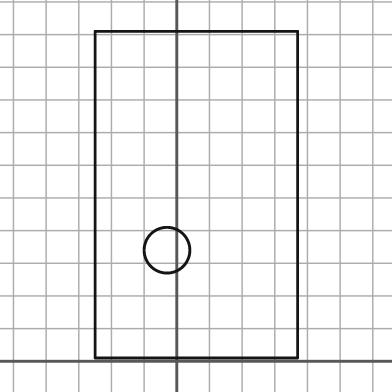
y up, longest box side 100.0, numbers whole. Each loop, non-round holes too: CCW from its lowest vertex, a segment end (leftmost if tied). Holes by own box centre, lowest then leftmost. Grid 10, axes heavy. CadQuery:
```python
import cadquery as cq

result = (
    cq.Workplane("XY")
    .moveTo(-25.0, 1.0)
    .lineTo(37.0, 1.0)
    .lineTo(37.0, 101.0)
    .lineTo(-25.0, 101.0)
    .close()
    .moveTo(-3.0, 34.0)
    .circle(7.0)
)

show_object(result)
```